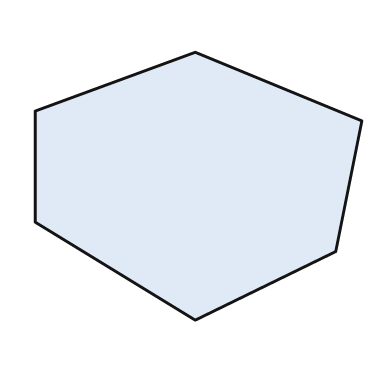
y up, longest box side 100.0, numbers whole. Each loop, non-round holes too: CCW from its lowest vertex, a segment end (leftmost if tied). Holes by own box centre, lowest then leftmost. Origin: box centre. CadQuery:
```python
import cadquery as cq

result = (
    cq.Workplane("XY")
    .moveTo(-1.0, -41.0)
    .lineTo(42.0, -20.0)
    .lineTo(50.0, 20.0)
    .lineTo(-1.0, 41.0)
    .lineTo(-50.0, 23.0)
    .lineTo(-50.0, -11.0)
    .close()
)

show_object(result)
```